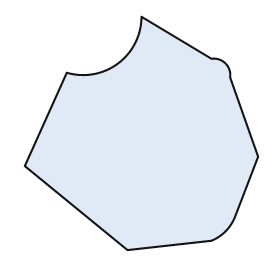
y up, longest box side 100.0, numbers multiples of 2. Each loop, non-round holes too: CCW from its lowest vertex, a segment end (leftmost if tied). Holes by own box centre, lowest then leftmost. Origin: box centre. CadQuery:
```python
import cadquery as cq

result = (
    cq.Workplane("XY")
    .moveTo(-6.0, -50.0)
    .lineTo(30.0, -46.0)
    .threePointArc((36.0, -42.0), (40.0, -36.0))
    .lineTo(50.0, -10.0)
    .lineTo(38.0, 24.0)
    .threePointArc((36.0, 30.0), (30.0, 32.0))
    .lineTo(0.0, 50.0)
    .threePointArc((-10.0, 30.0), (-32.0, 26.0))
    .lineTo(-50.0, -14.0)
    .close()
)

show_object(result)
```